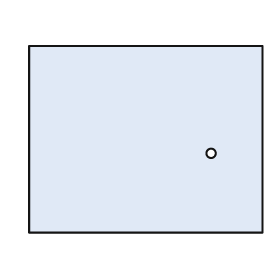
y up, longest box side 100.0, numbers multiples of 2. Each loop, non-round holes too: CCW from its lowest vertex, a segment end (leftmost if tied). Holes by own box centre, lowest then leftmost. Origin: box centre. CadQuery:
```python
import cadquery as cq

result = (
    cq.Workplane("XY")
    .moveTo(-50.0, -40.0)
    .lineTo(50.0, -40.0)
    .lineTo(50.0, 40.0)
    .lineTo(-50.0, 40.0)
    .close()
    .moveTo(28.0, -6.0)
    .circle(2.0)
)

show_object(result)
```